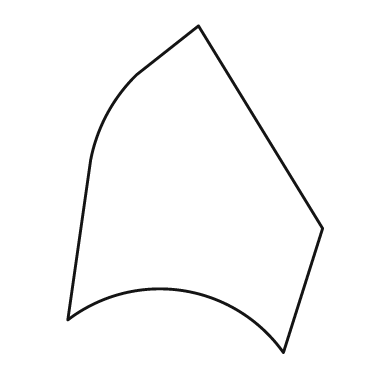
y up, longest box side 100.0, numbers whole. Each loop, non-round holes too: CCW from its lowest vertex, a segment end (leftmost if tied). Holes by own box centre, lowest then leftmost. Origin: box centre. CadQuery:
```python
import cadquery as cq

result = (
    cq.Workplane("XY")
    .moveTo(27.0, -50.0)
    .lineTo(39.0, -12.0)
    .lineTo(1.0, 50.0)
    .lineTo(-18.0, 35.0)
    .threePointArc((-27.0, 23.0), (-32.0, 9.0))
    .lineTo(-39.0, -40.0)
    .threePointArc((-4.0, -31.0), (27.0, -50.0))
    .close()
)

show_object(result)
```